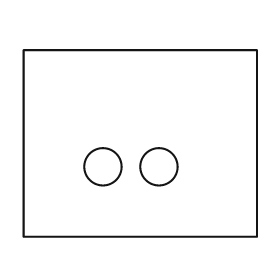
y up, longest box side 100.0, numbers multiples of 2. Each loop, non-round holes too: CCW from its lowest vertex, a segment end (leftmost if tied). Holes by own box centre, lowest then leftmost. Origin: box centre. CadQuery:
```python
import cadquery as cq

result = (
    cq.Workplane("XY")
    .moveTo(-50.0, -40.0)
    .lineTo(50.0, -40.0)
    .lineTo(50.0, 40.0)
    .lineTo(-50.0, 40.0)
    .close()
    .moveTo(-16.0, -10.0)
    .circle(8.0)
    .moveTo(8.0, -10.0)
    .circle(8.0)
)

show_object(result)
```